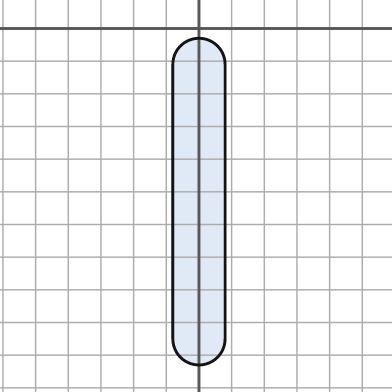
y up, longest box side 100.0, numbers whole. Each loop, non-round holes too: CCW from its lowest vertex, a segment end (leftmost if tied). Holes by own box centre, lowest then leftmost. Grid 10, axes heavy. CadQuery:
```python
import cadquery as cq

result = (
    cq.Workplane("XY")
    .moveTo(-8.0, -95.0)
    .threePointArc((0.0, -103.0), (8.0, -95.0))
    .lineTo(8.0, -11.0)
    .threePointArc((0.0, -3.0), (-8.0, -11.0))
    .close()
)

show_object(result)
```